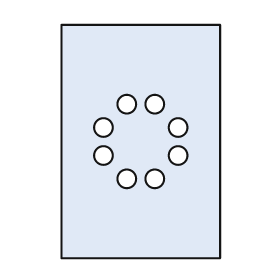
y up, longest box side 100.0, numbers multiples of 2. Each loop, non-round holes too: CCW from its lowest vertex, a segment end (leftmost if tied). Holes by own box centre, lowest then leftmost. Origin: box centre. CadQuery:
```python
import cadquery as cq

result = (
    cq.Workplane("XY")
    .moveTo(-34.0, -50.0)
    .lineTo(34.0, -50.0)
    .lineTo(34.0, 50.0)
    .lineTo(-34.0, 50.0)
    .close()
    .moveTo(-6.0, -16.0)
    .circle(4.0)
    .moveTo(6.0, -16.0)
    .circle(4.0)
    .moveTo(-16.0, -6.0)
    .circle(4.0)
    .moveTo(16.0, -6.0)
    .circle(4.0)
    .moveTo(-16.0, 6.0)
    .circle(4.0)
    .moveTo(16.0, 6.0)
    .circle(4.0)
    .moveTo(-6.0, 16.0)
    .circle(4.0)
    .moveTo(6.0, 16.0)
    .circle(4.0)
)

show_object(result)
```